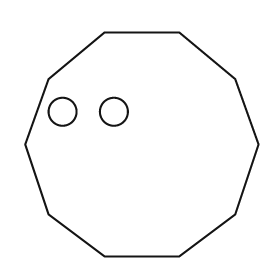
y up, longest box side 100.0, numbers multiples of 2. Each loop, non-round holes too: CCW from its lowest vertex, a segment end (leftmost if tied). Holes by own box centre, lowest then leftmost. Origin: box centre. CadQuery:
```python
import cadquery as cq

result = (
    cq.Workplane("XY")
    .moveTo(-16.0, -48.0)
    .lineTo(16.0, -48.0)
    .lineTo(40.0, -30.0)
    .lineTo(50.0, 0.0)
    .lineTo(40.0, 28.0)
    .lineTo(16.0, 48.0)
    .lineTo(-16.0, 48.0)
    .lineTo(-40.0, 28.0)
    .lineTo(-50.0, 0.0)
    .lineTo(-40.0, -30.0)
    .close()
    .moveTo(-34.0, 14.0)
    .circle(6.0)
    .moveTo(-12.0, 14.0)
    .circle(6.0)
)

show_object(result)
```